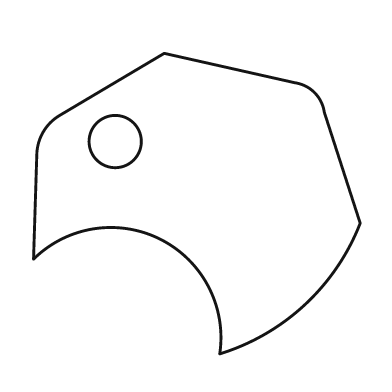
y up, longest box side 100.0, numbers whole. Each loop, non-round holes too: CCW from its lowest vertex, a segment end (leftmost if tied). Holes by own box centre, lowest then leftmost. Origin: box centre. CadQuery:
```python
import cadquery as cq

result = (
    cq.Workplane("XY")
    .moveTo(7.0, -46.0)
    .threePointArc((33.0, -31.0), (50.0, -6.0))
    .lineTo(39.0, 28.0)
    .threePointArc((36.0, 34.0), (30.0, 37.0))
    .lineTo(-10.0, 46.0)
    .lineTo(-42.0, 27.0)
    .threePointArc((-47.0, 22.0), (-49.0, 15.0))
    .lineTo(-50.0, -17.0)
    .threePointArc((-11.0, -11.0), (7.0, -46.0))
    .close()
    .moveTo(-25.0, 19.0)
    .circle(8.0)
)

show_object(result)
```